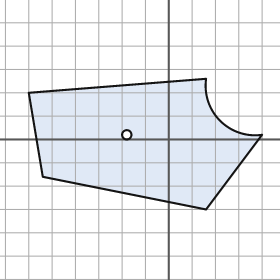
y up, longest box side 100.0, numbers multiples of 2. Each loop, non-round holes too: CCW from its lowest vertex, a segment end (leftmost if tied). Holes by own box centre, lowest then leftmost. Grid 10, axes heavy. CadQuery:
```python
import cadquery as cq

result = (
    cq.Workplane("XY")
    .moveTo(16.0, -30.0)
    .lineTo(40.0, 2.0)
    .threePointArc((22.0, 8.0), (16.0, 26.0))
    .lineTo(-60.0, 20.0)
    .lineTo(-54.0, -16.0)
    .close()
    .moveTo(-18.0, 2.0)
    .circle(2.0)
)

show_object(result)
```